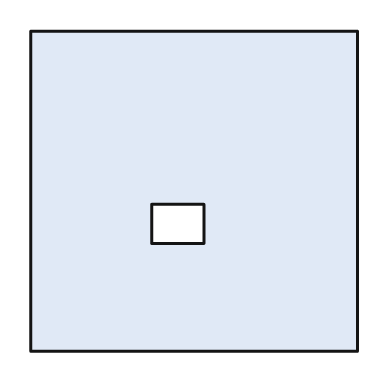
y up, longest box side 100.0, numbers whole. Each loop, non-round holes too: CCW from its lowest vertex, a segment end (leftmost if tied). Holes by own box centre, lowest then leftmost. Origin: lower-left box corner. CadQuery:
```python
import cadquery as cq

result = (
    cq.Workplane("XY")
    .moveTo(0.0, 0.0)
    .lineTo(100.0, 0.0)
    .lineTo(100.0, 98.0)
    .lineTo(0.0, 98.0)
    .close()
    .moveTo(37.0, 33.0)
    .lineTo(53.0, 33.0)
    .lineTo(53.0, 45.0)
    .lineTo(37.0, 45.0)
    .close()
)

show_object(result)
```